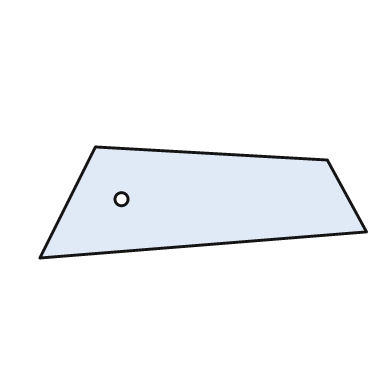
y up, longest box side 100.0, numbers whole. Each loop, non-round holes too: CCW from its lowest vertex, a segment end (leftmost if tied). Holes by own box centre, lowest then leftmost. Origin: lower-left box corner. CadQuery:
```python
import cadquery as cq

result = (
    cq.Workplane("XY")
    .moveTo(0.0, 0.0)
    .lineTo(100.0, 8.0)
    .lineTo(88.0, 30.0)
    .lineTo(17.0, 34.0)
    .close()
    .moveTo(25.0, 18.0)
    .circle(2.0)
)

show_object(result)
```